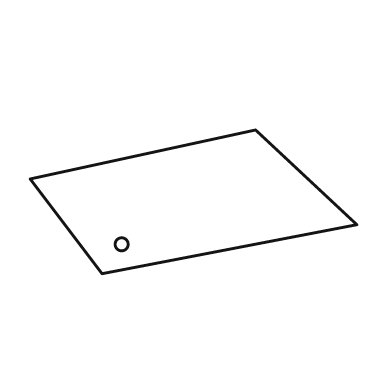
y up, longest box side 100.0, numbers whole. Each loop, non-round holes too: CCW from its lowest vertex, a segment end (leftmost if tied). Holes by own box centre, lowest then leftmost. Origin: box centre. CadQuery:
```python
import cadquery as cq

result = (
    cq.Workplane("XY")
    .moveTo(-28.0, -22.0)
    .lineTo(50.0, -7.0)
    .lineTo(19.0, 22.0)
    .lineTo(-50.0, 7.0)
    .close()
    .moveTo(-22.0, -13.0)
    .circle(2.0)
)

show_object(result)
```